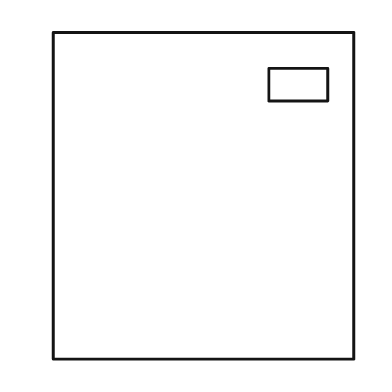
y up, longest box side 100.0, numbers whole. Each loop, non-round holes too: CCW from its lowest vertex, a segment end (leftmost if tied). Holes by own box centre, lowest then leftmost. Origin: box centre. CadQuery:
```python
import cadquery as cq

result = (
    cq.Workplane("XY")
    .moveTo(-46.0, -50.0)
    .lineTo(46.0, -50.0)
    .lineTo(46.0, 50.0)
    .lineTo(-46.0, 50.0)
    .close()
    .moveTo(20.0, 29.0)
    .lineTo(38.0, 29.0)
    .lineTo(38.0, 39.0)
    .lineTo(20.0, 39.0)
    .close()
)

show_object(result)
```